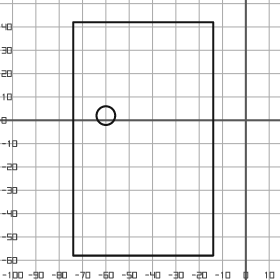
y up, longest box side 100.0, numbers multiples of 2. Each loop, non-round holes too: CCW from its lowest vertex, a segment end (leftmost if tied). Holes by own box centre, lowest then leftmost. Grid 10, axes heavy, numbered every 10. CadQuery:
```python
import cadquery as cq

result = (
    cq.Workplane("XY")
    .moveTo(-74.0, -58.0)
    .lineTo(-14.0, -58.0)
    .lineTo(-14.0, 42.0)
    .lineTo(-74.0, 42.0)
    .close()
    .moveTo(-60.0, 2.0)
    .circle(4.0)
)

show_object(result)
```